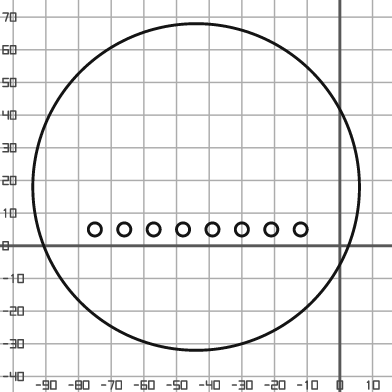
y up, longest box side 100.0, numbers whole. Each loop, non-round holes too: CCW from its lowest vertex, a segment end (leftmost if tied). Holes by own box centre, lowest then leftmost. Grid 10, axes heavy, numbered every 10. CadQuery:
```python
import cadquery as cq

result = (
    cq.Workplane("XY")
    .moveTo(-44.0, 18.0)
    .circle(50.0)
    .moveTo(-75.0, 5.0)
    .circle(2.0)
    .moveTo(-66.0, 5.0)
    .circle(2.0)
    .moveTo(-57.0, 5.0)
    .circle(2.0)
    .moveTo(-48.0, 5.0)
    .circle(2.0)
    .moveTo(-39.0, 5.0)
    .circle(2.0)
    .moveTo(-30.0, 5.0)
    .circle(2.0)
    .moveTo(-21.0, 5.0)
    .circle(2.0)
    .moveTo(-12.0, 5.0)
    .circle(2.0)
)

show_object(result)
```